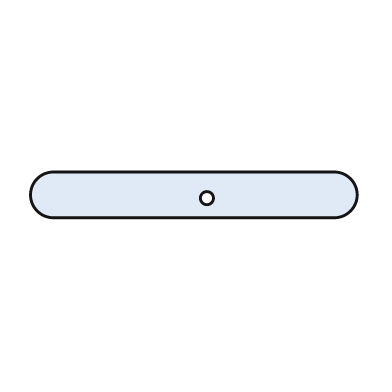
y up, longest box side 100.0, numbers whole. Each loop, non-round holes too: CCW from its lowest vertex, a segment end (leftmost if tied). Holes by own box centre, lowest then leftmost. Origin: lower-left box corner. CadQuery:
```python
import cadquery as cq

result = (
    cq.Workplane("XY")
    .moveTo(7.0, 0.0)
    .lineTo(93.0, 0.0)
    .threePointArc((100.0, 7.0), (93.0, 14.0))
    .lineTo(7.0, 14.0)
    .threePointArc((0.0, 7.0), (7.0, 0.0))
    .close()
    .moveTo(54.0, 6.0)
    .circle(2.0)
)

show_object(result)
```